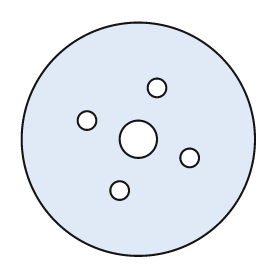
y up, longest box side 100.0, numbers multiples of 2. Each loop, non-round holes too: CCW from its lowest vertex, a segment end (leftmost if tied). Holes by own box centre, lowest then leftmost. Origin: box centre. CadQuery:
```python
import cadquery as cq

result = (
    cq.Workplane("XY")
    .moveTo(0.0, 0.0)
    .circle(50.0)
    .moveTo(-8.0, -22.0)
    .circle(4.0)
    .moveTo(22.0, -8.0)
    .circle(4.0)
    .moveTo(0.0, 0.0)
    .circle(8.0)
    .moveTo(-22.0, 8.0)
    .circle(4.0)
    .moveTo(8.0, 22.0)
    .circle(4.0)
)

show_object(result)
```